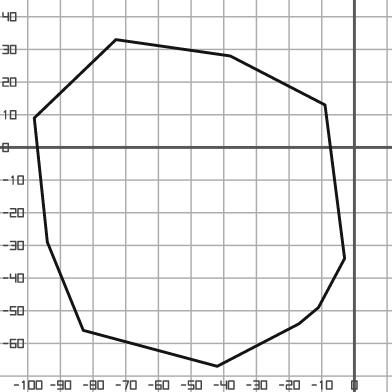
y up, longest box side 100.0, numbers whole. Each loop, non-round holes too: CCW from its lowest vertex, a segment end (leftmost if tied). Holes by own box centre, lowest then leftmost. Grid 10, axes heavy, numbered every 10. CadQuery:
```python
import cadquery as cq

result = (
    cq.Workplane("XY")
    .moveTo(-42.0, -67.0)
    .lineTo(-17.0, -54.0)
    .lineTo(-11.0, -49.0)
    .lineTo(-3.0, -34.0)
    .lineTo(-9.0, 13.0)
    .lineTo(-38.0, 28.0)
    .lineTo(-73.0, 33.0)
    .lineTo(-98.0, 9.0)
    .lineTo(-94.0, -29.0)
    .lineTo(-83.0, -56.0)
    .close()
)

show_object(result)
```